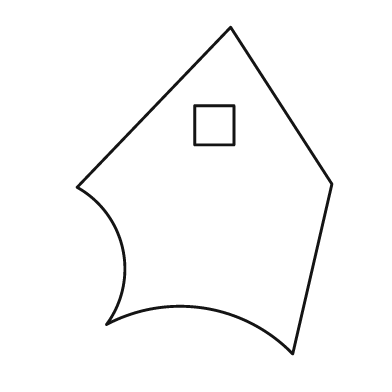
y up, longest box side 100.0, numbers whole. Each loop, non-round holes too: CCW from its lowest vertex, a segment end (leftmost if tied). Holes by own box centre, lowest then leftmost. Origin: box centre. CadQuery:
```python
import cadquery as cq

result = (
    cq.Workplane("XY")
    .moveTo(27.0, -50.0)
    .lineTo(39.0, 2.0)
    .lineTo(8.0, 50.0)
    .lineTo(-39.0, 1.0)
    .threePointArc((-25.0, -18.0), (-30.0, -41.0))
    .threePointArc((0.0, -36.0), (27.0, -50.0))
    .close()
    .moveTo(-3.0, 14.0)
    .lineTo(9.0, 14.0)
    .lineTo(9.0, 26.0)
    .lineTo(-3.0, 26.0)
    .close()
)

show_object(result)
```